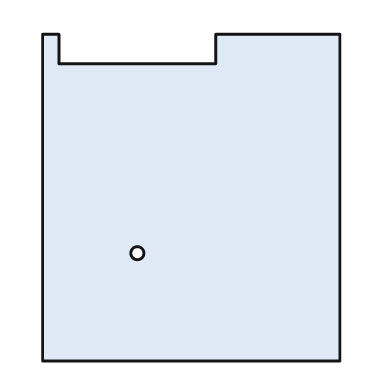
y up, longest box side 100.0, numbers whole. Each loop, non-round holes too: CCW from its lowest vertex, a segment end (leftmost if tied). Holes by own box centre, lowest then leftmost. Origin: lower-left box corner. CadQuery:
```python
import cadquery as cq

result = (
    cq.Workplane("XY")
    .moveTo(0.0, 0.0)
    .lineTo(91.0, 0.0)
    .lineTo(91.0, 100.0)
    .lineTo(53.0, 100.0)
    .lineTo(53.0, 91.0)
    .lineTo(5.0, 91.0)
    .lineTo(5.0, 100.0)
    .lineTo(0.0, 100.0)
    .close()
    .moveTo(29.0, 33.0)
    .circle(2.0)
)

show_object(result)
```